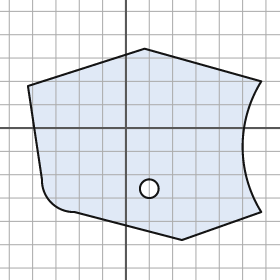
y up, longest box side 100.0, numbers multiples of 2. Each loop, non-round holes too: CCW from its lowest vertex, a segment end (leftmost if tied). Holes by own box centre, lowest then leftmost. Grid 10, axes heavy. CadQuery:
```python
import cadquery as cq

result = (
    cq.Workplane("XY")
    .moveTo(24.0, -48.0)
    .lineTo(58.0, -36.0)
    .threePointArc((50.0, -8.0), (58.0, 20.0))
    .lineTo(8.0, 34.0)
    .lineTo(-42.0, 18.0)
    .lineTo(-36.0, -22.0)
    .threePointArc((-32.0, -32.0), (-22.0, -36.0))
    .close()
    .moveTo(10.0, -26.0)
    .circle(4.0)
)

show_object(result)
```